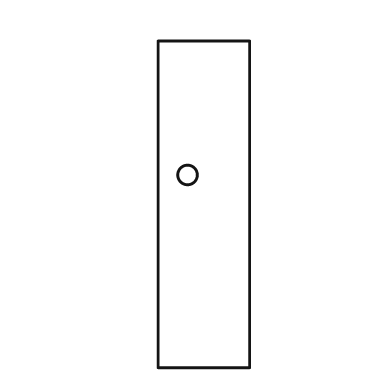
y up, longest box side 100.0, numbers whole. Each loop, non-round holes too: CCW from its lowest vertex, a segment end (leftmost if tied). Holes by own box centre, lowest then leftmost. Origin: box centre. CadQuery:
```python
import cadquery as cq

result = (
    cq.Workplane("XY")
    .moveTo(-14.0, -50.0)
    .lineTo(14.0, -50.0)
    .lineTo(14.0, 50.0)
    .lineTo(-14.0, 50.0)
    .close()
    .moveTo(-5.0, 9.0)
    .circle(3.0)
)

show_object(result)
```